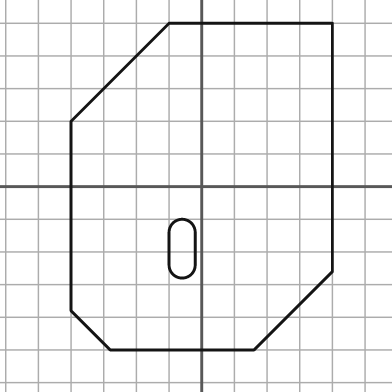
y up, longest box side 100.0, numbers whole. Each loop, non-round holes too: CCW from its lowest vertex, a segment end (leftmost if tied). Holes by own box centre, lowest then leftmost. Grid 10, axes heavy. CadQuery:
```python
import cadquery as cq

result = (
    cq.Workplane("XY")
    .moveTo(-28.0, -50.0)
    .lineTo(16.0, -50.0)
    .lineTo(40.0, -26.0)
    .lineTo(40.0, 50.0)
    .lineTo(-10.0, 50.0)
    .lineTo(-40.0, 20.0)
    .lineTo(-40.0, -38.0)
    .close()
    .moveTo(-10.0, -24.0)
    .threePointArc((-6.0, -28.0), (-2.0, -24.0))
    .lineTo(-2.0, -14.0)
    .threePointArc((-6.0, -10.0), (-10.0, -14.0))
    .close()
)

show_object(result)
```